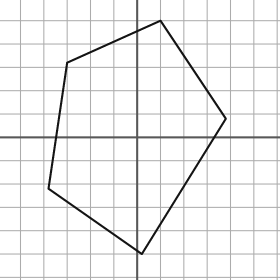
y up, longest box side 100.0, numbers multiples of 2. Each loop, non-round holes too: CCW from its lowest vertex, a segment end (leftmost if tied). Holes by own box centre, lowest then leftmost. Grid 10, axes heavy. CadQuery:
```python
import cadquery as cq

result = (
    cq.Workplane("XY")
    .moveTo(2.0, -50.0)
    .lineTo(38.0, 8.0)
    .lineTo(10.0, 50.0)
    .lineTo(-30.0, 32.0)
    .lineTo(-38.0, -22.0)
    .close()
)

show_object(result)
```